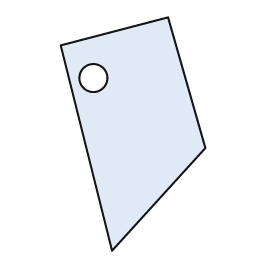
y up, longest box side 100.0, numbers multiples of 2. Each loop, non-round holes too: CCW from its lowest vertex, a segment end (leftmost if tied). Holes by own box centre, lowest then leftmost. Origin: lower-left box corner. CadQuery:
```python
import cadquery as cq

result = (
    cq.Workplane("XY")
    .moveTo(22.0, 0.0)
    .lineTo(62.0, 44.0)
    .lineTo(46.0, 100.0)
    .lineTo(0.0, 88.0)
    .close()
    .moveTo(14.0, 74.0)
    .circle(6.0)
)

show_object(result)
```